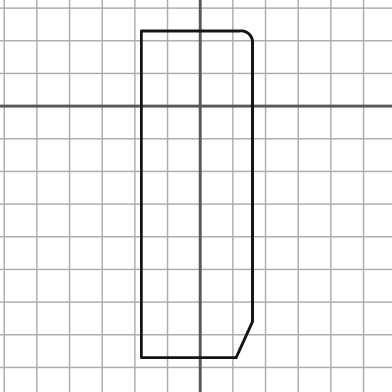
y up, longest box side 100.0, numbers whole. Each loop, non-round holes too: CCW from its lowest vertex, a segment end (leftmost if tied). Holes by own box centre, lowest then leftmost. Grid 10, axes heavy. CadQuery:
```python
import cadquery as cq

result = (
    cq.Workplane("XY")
    .moveTo(-18.0, -77.0)
    .lineTo(11.0, -77.0)
    .lineTo(16.0, -66.0)
    .lineTo(16.0, 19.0)
    .threePointArc((15.0, 22.0), (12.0, 23.0))
    .lineTo(-18.0, 23.0)
    .close()
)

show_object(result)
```